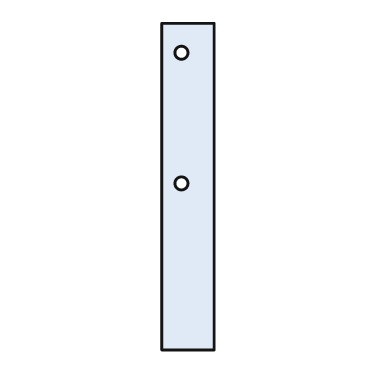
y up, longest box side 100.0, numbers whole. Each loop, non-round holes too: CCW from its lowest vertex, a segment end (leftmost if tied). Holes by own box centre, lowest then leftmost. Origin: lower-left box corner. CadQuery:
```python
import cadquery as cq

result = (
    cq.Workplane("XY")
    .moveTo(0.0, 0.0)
    .lineTo(16.0, 0.0)
    .lineTo(16.0, 100.0)
    .lineTo(0.0, 100.0)
    .close()
    .moveTo(6.0, 51.0)
    .circle(2.0)
    .moveTo(6.0, 91.0)
    .circle(2.0)
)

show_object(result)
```